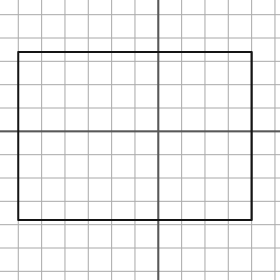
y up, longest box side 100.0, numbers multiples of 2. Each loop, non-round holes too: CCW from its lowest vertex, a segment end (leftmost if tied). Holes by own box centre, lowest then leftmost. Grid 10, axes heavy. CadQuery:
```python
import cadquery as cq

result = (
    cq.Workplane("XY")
    .moveTo(-60.0, -38.0)
    .lineTo(40.0, -38.0)
    .lineTo(40.0, 34.0)
    .lineTo(-60.0, 34.0)
    .close()
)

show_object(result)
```